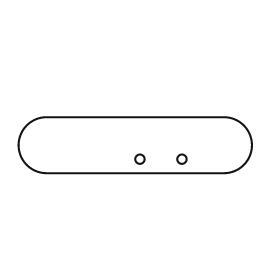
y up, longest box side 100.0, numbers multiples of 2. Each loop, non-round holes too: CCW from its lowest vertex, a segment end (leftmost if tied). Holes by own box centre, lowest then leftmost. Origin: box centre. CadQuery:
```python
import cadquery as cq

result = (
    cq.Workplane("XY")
    .moveTo(-38.0, -12.0)
    .lineTo(38.0, -12.0)
    .threePointArc((50.0, 0.0), (38.0, 12.0))
    .lineTo(-38.0, 12.0)
    .threePointArc((-50.0, 0.0), (-38.0, -12.0))
    .close()
    .moveTo(2.0, -6.0)
    .circle(2.0)
    .moveTo(20.0, -6.0)
    .circle(2.0)
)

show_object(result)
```